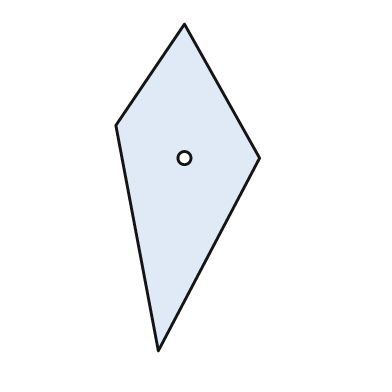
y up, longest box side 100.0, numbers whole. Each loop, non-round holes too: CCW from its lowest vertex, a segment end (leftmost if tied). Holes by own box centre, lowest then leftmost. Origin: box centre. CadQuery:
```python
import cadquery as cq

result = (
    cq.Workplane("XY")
    .moveTo(-9.0, -50.0)
    .lineTo(22.0, 9.0)
    .lineTo(-1.0, 50.0)
    .lineTo(-22.0, 19.0)
    .close()
    .moveTo(-1.0, 9.0)
    .circle(2.0)
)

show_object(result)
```